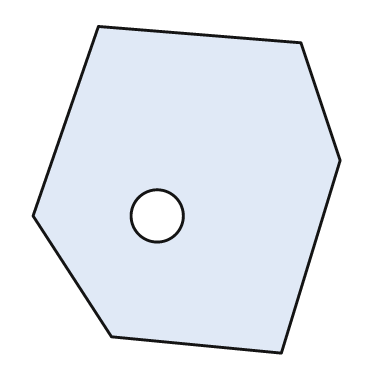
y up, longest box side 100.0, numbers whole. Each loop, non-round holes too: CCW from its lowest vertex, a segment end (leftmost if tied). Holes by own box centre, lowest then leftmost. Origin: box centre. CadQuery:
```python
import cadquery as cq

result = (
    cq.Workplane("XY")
    .moveTo(29.0, -50.0)
    .lineTo(47.0, 9.0)
    .lineTo(35.0, 45.0)
    .lineTo(-27.0, 50.0)
    .lineTo(-47.0, -8.0)
    .lineTo(-23.0, -45.0)
    .close()
    .moveTo(-9.0, -8.0)
    .circle(8.0)
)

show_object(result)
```